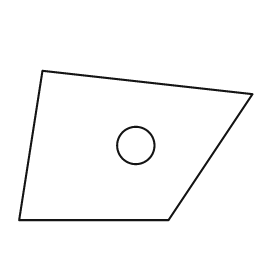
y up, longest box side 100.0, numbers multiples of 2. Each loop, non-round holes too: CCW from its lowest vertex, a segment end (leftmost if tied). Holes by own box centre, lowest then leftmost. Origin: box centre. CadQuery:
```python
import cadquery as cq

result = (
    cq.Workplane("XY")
    .moveTo(-50.0, -32.0)
    .lineTo(14.0, -32.0)
    .lineTo(50.0, 22.0)
    .lineTo(-40.0, 32.0)
    .close()
    .moveTo(0.0, 0.0)
    .circle(8.0)
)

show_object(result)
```